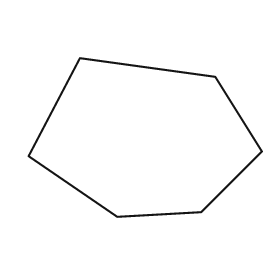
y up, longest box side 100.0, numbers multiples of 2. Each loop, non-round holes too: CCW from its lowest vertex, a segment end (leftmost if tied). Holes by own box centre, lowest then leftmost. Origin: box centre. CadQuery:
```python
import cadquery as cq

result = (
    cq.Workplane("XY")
    .moveTo(-12.0, -34.0)
    .lineTo(24.0, -32.0)
    .lineTo(50.0, -6.0)
    .lineTo(30.0, 26.0)
    .lineTo(-28.0, 34.0)
    .lineTo(-50.0, -8.0)
    .close()
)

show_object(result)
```